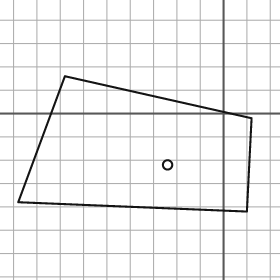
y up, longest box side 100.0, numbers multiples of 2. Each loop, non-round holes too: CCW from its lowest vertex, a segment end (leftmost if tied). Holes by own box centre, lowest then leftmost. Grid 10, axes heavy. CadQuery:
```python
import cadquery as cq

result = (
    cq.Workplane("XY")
    .moveTo(10.0, -42.0)
    .lineTo(12.0, -2.0)
    .lineTo(-68.0, 16.0)
    .lineTo(-88.0, -38.0)
    .close()
    .moveTo(-24.0, -22.0)
    .circle(2.0)
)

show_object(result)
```